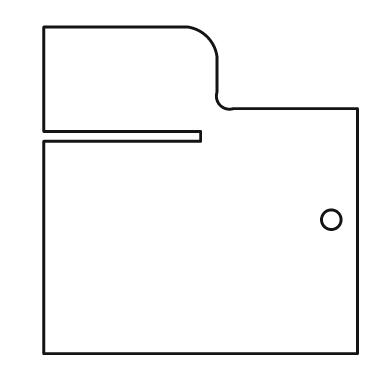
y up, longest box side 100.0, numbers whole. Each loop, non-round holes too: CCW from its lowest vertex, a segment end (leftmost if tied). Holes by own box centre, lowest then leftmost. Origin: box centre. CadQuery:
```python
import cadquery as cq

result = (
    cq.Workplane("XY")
    .moveTo(-48.0, -50.0)
    .lineTo(48.0, -50.0)
    .lineTo(48.0, 25.0)
    .lineTo(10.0, 25.0)
    .threePointArc((6.0, 26.0), (5.0, 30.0))
    .lineTo(5.0, 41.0)
    .threePointArc((2.0, 47.0), (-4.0, 50.0))
    .lineTo(-48.0, 50.0)
    .lineTo(-48.0, 18.0)
    .lineTo(0.0, 18.0)
    .lineTo(0.0, 15.0)
    .lineTo(-48.0, 15.0)
    .close()
    .moveTo(40.0, -9.0)
    .circle(3.0)
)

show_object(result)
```